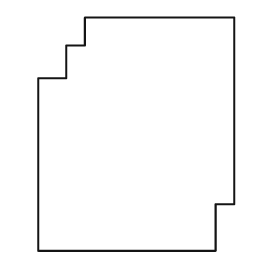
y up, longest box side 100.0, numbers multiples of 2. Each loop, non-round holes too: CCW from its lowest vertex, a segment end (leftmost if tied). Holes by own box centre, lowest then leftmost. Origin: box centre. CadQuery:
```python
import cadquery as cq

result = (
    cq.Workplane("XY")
    .moveTo(-42.0, -50.0)
    .lineTo(34.0, -50.0)
    .lineTo(34.0, -30.0)
    .lineTo(42.0, -30.0)
    .lineTo(42.0, 50.0)
    .lineTo(-22.0, 50.0)
    .lineTo(-22.0, 38.0)
    .lineTo(-30.0, 38.0)
    .lineTo(-30.0, 24.0)
    .lineTo(-42.0, 24.0)
    .close()
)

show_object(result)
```